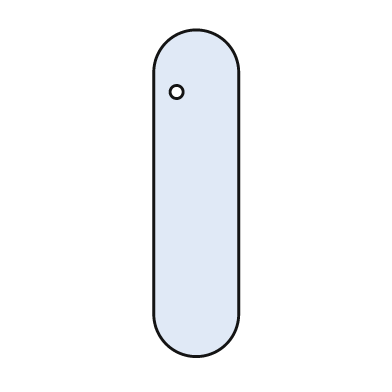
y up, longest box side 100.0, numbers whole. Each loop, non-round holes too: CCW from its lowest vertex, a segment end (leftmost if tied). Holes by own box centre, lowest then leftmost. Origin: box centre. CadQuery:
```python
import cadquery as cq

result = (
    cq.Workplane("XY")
    .moveTo(-13.0, -37.0)
    .threePointArc((0.0, -50.0), (13.0, -37.0))
    .lineTo(13.0, 37.0)
    .threePointArc((0.0, 50.0), (-13.0, 37.0))
    .close()
    .moveTo(-6.0, 31.0)
    .circle(2.0)
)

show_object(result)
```